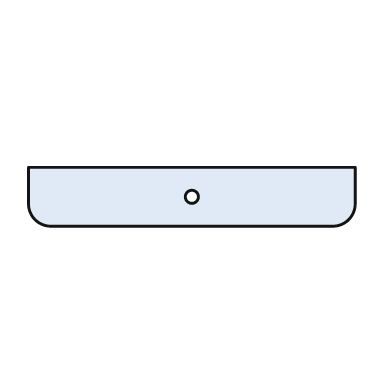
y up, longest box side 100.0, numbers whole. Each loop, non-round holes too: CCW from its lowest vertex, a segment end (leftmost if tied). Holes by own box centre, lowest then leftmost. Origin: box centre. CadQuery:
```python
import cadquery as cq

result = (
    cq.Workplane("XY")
    .moveTo(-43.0, -9.0)
    .lineTo(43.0, -9.0)
    .threePointArc((48.0, -7.0), (50.0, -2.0))
    .lineTo(50.0, 9.0)
    .lineTo(-50.0, 9.0)
    .lineTo(-50.0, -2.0)
    .threePointArc((-48.0, -7.0), (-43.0, -9.0))
    .close()
    .moveTo(0.0, 0.0)
    .circle(2.0)
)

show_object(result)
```